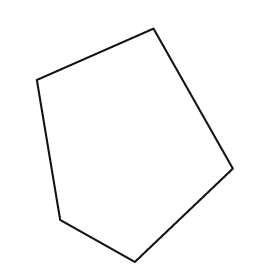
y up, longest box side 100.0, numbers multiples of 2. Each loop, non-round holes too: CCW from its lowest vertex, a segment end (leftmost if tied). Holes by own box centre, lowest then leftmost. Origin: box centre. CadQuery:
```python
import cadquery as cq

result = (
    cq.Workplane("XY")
    .moveTo(0.0, -50.0)
    .lineTo(42.0, -10.0)
    .lineTo(8.0, 50.0)
    .lineTo(-42.0, 28.0)
    .lineTo(-32.0, -32.0)
    .close()
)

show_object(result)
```